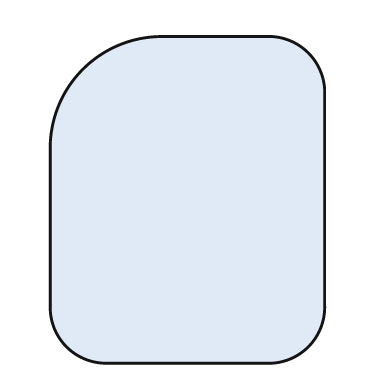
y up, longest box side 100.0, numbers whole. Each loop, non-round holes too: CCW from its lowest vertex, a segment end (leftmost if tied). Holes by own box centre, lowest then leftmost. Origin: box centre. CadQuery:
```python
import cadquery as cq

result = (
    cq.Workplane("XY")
    .moveTo(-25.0, -50.0)
    .lineTo(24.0, -50.0)
    .threePointArc((37.0, -45.0), (42.0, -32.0))
    .lineTo(42.0, 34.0)
    .threePointArc((37.0, 45.0), (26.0, 50.0))
    .lineTo(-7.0, 50.0)
    .threePointArc((-32.0, 40.0), (-42.0, 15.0))
    .lineTo(-42.0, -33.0)
    .threePointArc((-37.0, -45.0), (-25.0, -50.0))
    .close()
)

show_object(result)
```